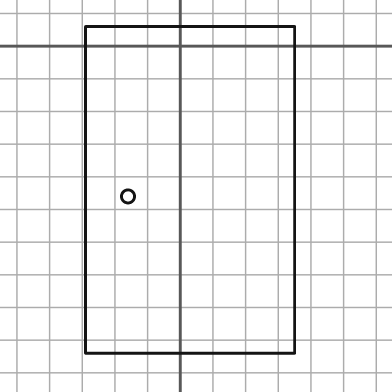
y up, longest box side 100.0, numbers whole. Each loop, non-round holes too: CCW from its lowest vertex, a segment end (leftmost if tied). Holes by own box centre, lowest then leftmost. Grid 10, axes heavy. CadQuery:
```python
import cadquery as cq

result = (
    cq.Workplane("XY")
    .moveTo(-29.0, -94.0)
    .lineTo(35.0, -94.0)
    .lineTo(35.0, 6.0)
    .lineTo(-29.0, 6.0)
    .close()
    .moveTo(-16.0, -46.0)
    .circle(2.0)
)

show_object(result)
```